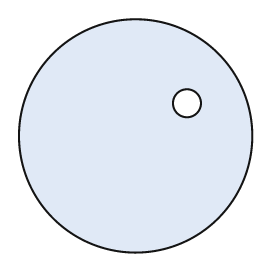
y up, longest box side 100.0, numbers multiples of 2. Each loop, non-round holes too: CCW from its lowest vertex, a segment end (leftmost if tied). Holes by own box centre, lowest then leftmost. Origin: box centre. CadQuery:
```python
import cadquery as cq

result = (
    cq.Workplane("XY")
    .moveTo(0.0, 0.0)
    .circle(50.0)
    .moveTo(22.0, 14.0)
    .circle(6.0)
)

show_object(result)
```